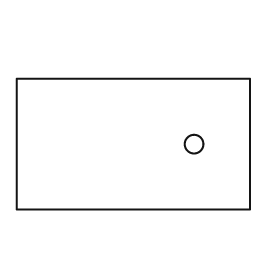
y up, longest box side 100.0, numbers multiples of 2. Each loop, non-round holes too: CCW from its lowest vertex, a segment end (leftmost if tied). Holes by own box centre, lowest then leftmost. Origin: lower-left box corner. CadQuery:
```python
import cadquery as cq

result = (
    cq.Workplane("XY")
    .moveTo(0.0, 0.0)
    .lineTo(100.0, 0.0)
    .lineTo(100.0, 56.0)
    .lineTo(0.0, 56.0)
    .close()
    .moveTo(76.0, 28.0)
    .circle(4.0)
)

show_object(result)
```